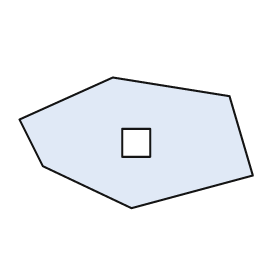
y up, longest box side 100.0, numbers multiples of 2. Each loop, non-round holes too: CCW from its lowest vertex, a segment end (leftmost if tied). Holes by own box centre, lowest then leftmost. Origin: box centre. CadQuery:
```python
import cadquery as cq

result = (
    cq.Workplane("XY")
    .moveTo(-2.0, -28.0)
    .lineTo(50.0, -14.0)
    .lineTo(40.0, 20.0)
    .lineTo(-10.0, 28.0)
    .lineTo(-50.0, 10.0)
    .lineTo(-40.0, -10.0)
    .close()
    .moveTo(-6.0, -6.0)
    .lineTo(6.0, -6.0)
    .lineTo(6.0, 6.0)
    .lineTo(-6.0, 6.0)
    .close()
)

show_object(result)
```